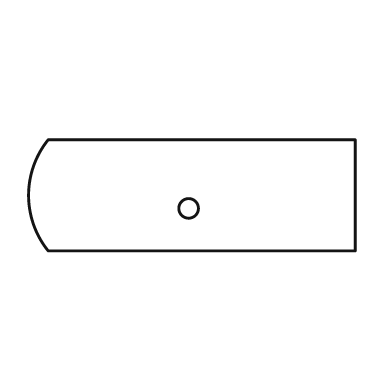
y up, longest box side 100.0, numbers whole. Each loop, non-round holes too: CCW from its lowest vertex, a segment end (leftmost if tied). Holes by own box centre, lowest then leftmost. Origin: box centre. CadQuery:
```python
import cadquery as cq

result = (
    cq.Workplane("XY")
    .moveTo(-44.0, -17.0)
    .lineTo(50.0, -17.0)
    .lineTo(50.0, 17.0)
    .lineTo(-44.0, 17.0)
    .threePointArc((-50.0, 0.0), (-44.0, -17.0))
    .close()
    .moveTo(-1.0, -4.0)
    .circle(3.0)
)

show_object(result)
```